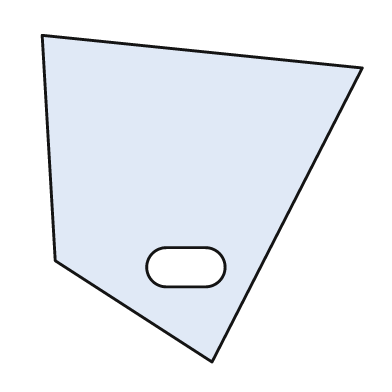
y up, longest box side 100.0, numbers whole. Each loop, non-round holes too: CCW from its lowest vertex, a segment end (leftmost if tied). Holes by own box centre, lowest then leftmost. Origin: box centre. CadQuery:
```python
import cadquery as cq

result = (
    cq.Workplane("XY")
    .moveTo(3.0, -50.0)
    .lineTo(49.0, 40.0)
    .lineTo(-49.0, 50.0)
    .lineTo(-45.0, -19.0)
    .close()
    .moveTo(-11.0, -27.0)
    .lineTo(1.0, -27.0)
    .threePointArc((7.0, -21.0), (1.0, -15.0))
    .lineTo(-11.0, -15.0)
    .threePointArc((-17.0, -21.0), (-11.0, -27.0))
    .close()
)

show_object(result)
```